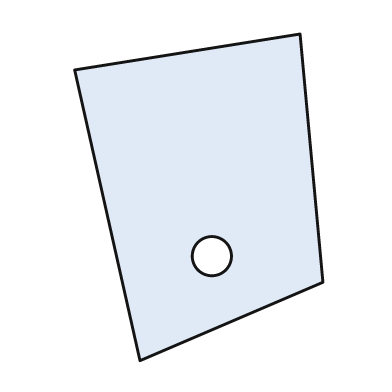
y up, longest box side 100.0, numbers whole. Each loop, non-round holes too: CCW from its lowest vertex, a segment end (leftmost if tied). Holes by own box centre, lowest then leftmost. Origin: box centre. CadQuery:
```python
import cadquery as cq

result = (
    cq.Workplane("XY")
    .moveTo(-18.0, -50.0)
    .lineTo(38.0, -26.0)
    .lineTo(31.0, 50.0)
    .lineTo(-38.0, 39.0)
    .close()
    .moveTo(4.0, -18.0)
    .circle(6.0)
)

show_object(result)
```